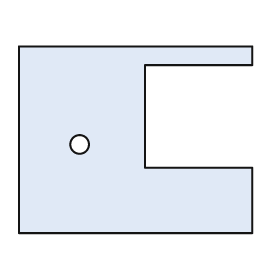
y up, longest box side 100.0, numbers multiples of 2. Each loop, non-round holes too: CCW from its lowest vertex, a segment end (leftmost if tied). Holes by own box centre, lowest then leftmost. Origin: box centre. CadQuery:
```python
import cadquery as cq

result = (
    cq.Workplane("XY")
    .moveTo(-50.0, -40.0)
    .lineTo(50.0, -40.0)
    .lineTo(50.0, -12.0)
    .lineTo(4.0, -12.0)
    .lineTo(4.0, 32.0)
    .lineTo(50.0, 32.0)
    .lineTo(50.0, 40.0)
    .lineTo(-50.0, 40.0)
    .close()
    .moveTo(-24.0, -2.0)
    .circle(4.0)
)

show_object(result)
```